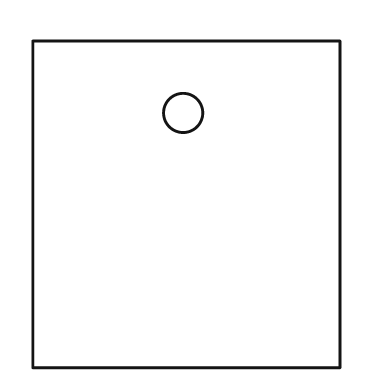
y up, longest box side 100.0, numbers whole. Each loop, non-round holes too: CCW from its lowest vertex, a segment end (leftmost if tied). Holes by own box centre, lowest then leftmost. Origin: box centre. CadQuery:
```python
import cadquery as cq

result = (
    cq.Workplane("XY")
    .moveTo(-47.0, -50.0)
    .lineTo(47.0, -50.0)
    .lineTo(47.0, 50.0)
    .lineTo(-47.0, 50.0)
    .close()
    .moveTo(-1.0, 28.0)
    .circle(6.0)
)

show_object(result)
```